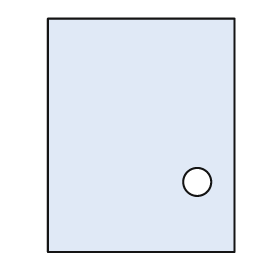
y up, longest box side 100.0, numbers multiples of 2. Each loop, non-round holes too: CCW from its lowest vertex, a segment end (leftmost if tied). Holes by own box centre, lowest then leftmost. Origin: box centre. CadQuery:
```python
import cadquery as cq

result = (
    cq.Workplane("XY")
    .moveTo(-40.0, -50.0)
    .lineTo(40.0, -50.0)
    .lineTo(40.0, 50.0)
    .lineTo(-40.0, 50.0)
    .close()
    .moveTo(24.0, -20.0)
    .circle(6.0)
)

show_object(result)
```